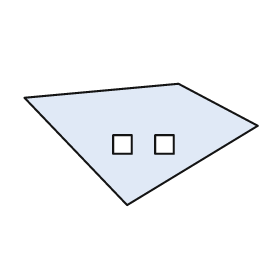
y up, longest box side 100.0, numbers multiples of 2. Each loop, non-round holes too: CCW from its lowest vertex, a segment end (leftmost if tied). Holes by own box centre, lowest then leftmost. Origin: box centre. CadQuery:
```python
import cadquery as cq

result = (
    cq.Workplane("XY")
    .moveTo(-6.0, -26.0)
    .lineTo(50.0, 8.0)
    .lineTo(16.0, 26.0)
    .lineTo(-50.0, 20.0)
    .close()
    .moveTo(-12.0, -4.0)
    .lineTo(-4.0, -4.0)
    .lineTo(-4.0, 4.0)
    .lineTo(-12.0, 4.0)
    .close()
    .moveTo(6.0, -4.0)
    .lineTo(14.0, -4.0)
    .lineTo(14.0, 4.0)
    .lineTo(6.0, 4.0)
    .close()
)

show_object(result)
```